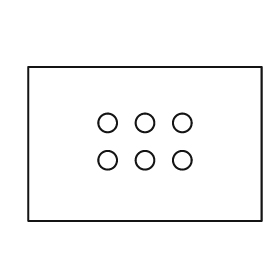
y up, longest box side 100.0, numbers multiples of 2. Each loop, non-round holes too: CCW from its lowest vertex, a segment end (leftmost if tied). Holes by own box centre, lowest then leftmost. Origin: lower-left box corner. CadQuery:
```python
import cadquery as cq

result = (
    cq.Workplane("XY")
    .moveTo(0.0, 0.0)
    .lineTo(100.0, 0.0)
    .lineTo(100.0, 66.0)
    .lineTo(0.0, 66.0)
    .close()
    .moveTo(34.0, 26.0)
    .circle(4.0)
    .moveTo(50.0, 26.0)
    .circle(4.0)
    .moveTo(66.0, 26.0)
    .circle(4.0)
    .moveTo(34.0, 42.0)
    .circle(4.0)
    .moveTo(50.0, 42.0)
    .circle(4.0)
    .moveTo(66.0, 42.0)
    .circle(4.0)
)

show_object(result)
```